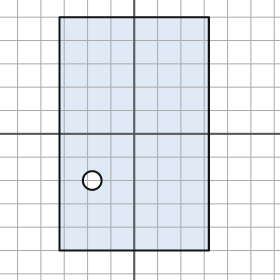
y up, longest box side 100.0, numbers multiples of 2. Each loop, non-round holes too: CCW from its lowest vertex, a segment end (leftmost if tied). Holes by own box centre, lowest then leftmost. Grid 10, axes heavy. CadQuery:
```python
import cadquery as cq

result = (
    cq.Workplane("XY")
    .moveTo(-32.0, -50.0)
    .lineTo(32.0, -50.0)
    .lineTo(32.0, 50.0)
    .lineTo(-32.0, 50.0)
    .close()
    .moveTo(-18.0, -20.0)
    .circle(4.0)
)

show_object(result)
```